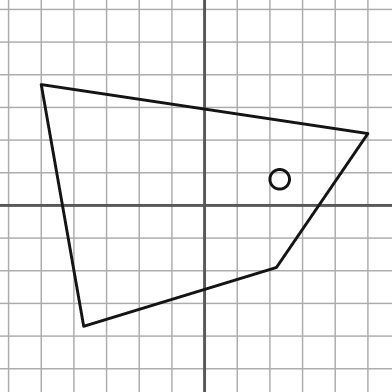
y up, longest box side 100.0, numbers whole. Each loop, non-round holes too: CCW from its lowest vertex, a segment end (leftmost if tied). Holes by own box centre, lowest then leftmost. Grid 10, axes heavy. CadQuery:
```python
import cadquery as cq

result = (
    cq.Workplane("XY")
    .moveTo(-37.0, -37.0)
    .lineTo(22.0, -19.0)
    .lineTo(50.0, 22.0)
    .lineTo(-50.0, 37.0)
    .close()
    .moveTo(23.0, 8.0)
    .circle(3.0)
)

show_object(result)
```